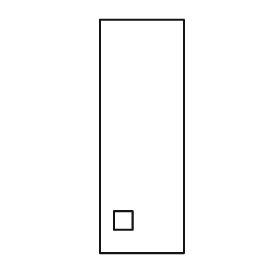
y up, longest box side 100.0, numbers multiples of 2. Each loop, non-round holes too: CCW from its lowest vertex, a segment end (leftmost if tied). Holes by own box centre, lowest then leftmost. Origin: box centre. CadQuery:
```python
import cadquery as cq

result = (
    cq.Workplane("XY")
    .moveTo(-18.0, -50.0)
    .lineTo(18.0, -50.0)
    .lineTo(18.0, 50.0)
    .lineTo(-18.0, 50.0)
    .close()
    .moveTo(-12.0, -40.0)
    .lineTo(-4.0, -40.0)
    .lineTo(-4.0, -32.0)
    .lineTo(-12.0, -32.0)
    .close()
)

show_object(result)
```